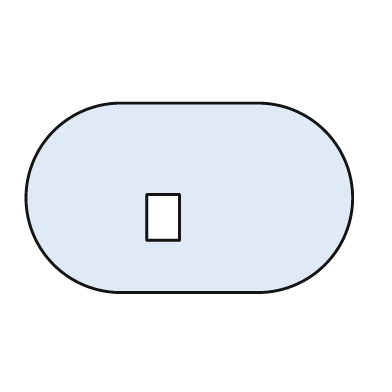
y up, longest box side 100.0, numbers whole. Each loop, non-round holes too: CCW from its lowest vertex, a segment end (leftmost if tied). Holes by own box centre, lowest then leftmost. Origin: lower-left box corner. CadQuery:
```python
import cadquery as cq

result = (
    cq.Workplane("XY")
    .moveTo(29.0, 0.0)
    .lineTo(71.0, 0.0)
    .threePointArc((100.0, 29.0), (71.0, 58.0))
    .lineTo(29.0, 58.0)
    .threePointArc((0.0, 29.0), (29.0, 0.0))
    .close()
    .moveTo(37.0, 16.0)
    .lineTo(47.0, 16.0)
    .lineTo(47.0, 30.0)
    .lineTo(37.0, 30.0)
    .close()
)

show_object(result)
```